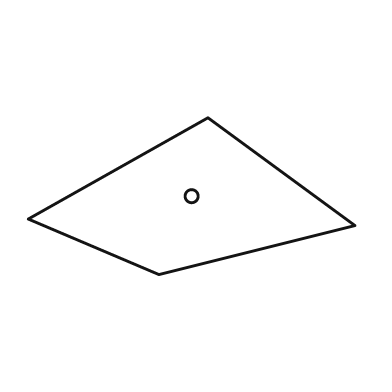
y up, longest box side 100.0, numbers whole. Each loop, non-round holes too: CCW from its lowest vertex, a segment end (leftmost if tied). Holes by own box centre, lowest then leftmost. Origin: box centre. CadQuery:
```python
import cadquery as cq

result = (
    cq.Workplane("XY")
    .moveTo(-10.0, -24.0)
    .lineTo(50.0, -9.0)
    .lineTo(5.0, 24.0)
    .lineTo(-50.0, -7.0)
    .close()
    .moveTo(0.0, 0.0)
    .circle(2.0)
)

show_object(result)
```